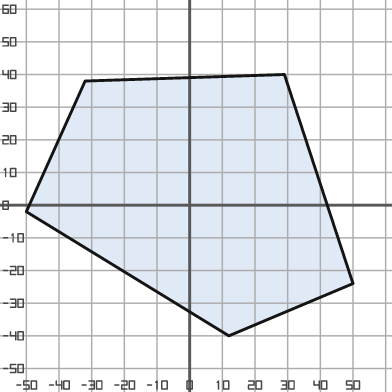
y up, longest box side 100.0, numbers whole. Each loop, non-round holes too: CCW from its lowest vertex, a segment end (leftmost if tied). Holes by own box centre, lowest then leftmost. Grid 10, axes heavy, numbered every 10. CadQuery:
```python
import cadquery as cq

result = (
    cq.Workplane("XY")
    .moveTo(12.0, -40.0)
    .lineTo(50.0, -24.0)
    .lineTo(29.0, 40.0)
    .lineTo(-32.0, 38.0)
    .lineTo(-50.0, -2.0)
    .close()
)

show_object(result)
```